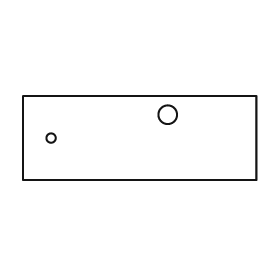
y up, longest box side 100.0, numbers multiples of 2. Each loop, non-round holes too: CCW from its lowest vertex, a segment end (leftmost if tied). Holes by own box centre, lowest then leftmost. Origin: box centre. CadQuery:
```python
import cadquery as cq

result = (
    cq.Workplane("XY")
    .moveTo(-50.0, -18.0)
    .lineTo(50.0, -18.0)
    .lineTo(50.0, 18.0)
    .lineTo(-50.0, 18.0)
    .close()
    .moveTo(-38.0, 0.0)
    .circle(2.0)
    .moveTo(12.0, 10.0)
    .circle(4.0)
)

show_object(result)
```